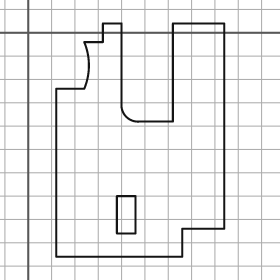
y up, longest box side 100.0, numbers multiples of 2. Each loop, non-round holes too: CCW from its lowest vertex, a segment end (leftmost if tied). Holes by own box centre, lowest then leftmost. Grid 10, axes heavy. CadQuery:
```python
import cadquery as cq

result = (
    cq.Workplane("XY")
    .moveTo(12.0, -96.0)
    .lineTo(66.0, -96.0)
    .lineTo(66.0, -84.0)
    .lineTo(84.0, -84.0)
    .lineTo(84.0, 4.0)
    .lineTo(62.0, 4.0)
    .lineTo(62.0, -38.0)
    .lineTo(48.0, -38.0)
    .threePointArc((42.0, -36.0), (40.0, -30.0))
    .lineTo(40.0, 4.0)
    .lineTo(32.0, 4.0)
    .lineTo(32.0, -4.0)
    .lineTo(24.0, -4.0)
    .threePointArc((26.0, -14.0), (24.0, -24.0))
    .lineTo(12.0, -24.0)
    .close()
    .moveTo(38.0, -86.0)
    .lineTo(46.0, -86.0)
    .lineTo(46.0, -70.0)
    .lineTo(38.0, -70.0)
    .close()
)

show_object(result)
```